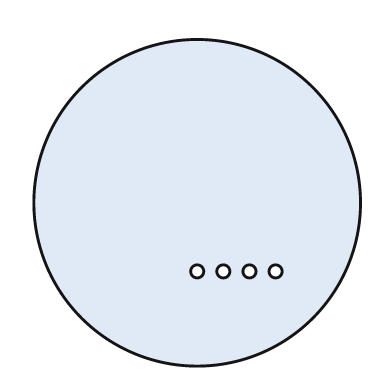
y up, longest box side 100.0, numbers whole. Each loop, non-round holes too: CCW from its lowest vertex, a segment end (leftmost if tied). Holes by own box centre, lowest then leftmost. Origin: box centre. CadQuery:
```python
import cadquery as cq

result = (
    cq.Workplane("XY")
    .moveTo(0.0, 0.0)
    .circle(50.0)
    .moveTo(0.0, -21.0)
    .circle(2.0)
    .moveTo(8.0, -21.0)
    .circle(2.0)
    .moveTo(16.0, -21.0)
    .circle(2.0)
    .moveTo(24.0, -21.0)
    .circle(2.0)
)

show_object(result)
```